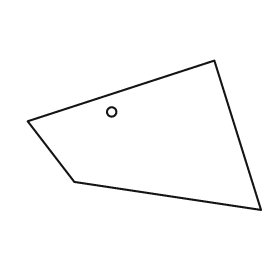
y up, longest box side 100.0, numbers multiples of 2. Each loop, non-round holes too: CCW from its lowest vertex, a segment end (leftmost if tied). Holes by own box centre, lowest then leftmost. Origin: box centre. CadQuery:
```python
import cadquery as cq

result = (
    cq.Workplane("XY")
    .moveTo(50.0, -32.0)
    .lineTo(30.0, 32.0)
    .lineTo(-50.0, 6.0)
    .lineTo(-30.0, -20.0)
    .close()
    .moveTo(-14.0, 10.0)
    .circle(2.0)
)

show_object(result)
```